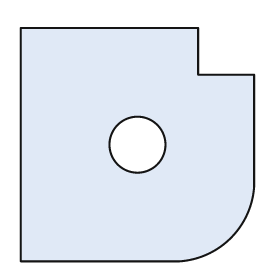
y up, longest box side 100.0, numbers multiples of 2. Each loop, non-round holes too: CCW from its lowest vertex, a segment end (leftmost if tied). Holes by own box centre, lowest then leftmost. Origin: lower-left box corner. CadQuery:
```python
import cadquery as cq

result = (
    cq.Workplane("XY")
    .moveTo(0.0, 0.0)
    .lineTo(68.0, 0.0)
    .threePointArc((90.0, 10.0), (100.0, 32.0))
    .lineTo(100.0, 80.0)
    .lineTo(76.0, 80.0)
    .lineTo(76.0, 100.0)
    .lineTo(0.0, 100.0)
    .close()
    .moveTo(50.0, 50.0)
    .circle(12.0)
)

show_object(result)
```